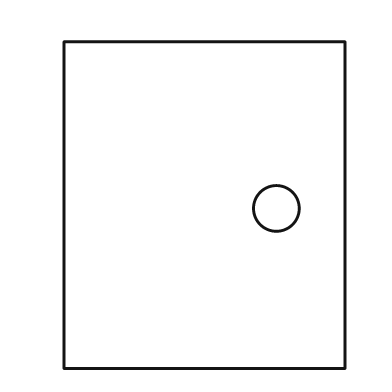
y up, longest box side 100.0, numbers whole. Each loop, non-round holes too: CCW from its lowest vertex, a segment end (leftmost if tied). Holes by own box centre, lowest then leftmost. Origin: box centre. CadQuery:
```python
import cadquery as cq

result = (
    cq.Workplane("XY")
    .moveTo(-43.0, -50.0)
    .lineTo(43.0, -50.0)
    .lineTo(43.0, 50.0)
    .lineTo(-43.0, 50.0)
    .close()
    .moveTo(22.0, -1.0)
    .circle(7.0)
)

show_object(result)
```